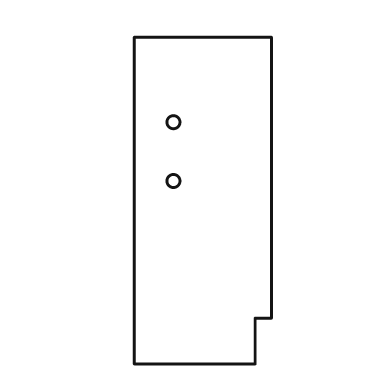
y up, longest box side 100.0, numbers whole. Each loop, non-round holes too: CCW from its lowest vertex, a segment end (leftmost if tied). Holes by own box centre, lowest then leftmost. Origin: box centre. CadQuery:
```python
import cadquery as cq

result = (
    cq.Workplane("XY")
    .moveTo(-21.0, -50.0)
    .lineTo(16.0, -50.0)
    .lineTo(16.0, -36.0)
    .lineTo(21.0, -36.0)
    .lineTo(21.0, 50.0)
    .lineTo(-21.0, 50.0)
    .close()
    .moveTo(-9.0, 6.0)
    .circle(2.0)
    .moveTo(-9.0, 24.0)
    .circle(2.0)
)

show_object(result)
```